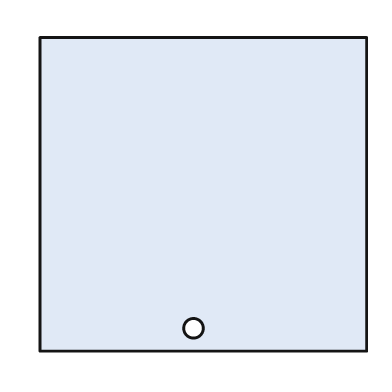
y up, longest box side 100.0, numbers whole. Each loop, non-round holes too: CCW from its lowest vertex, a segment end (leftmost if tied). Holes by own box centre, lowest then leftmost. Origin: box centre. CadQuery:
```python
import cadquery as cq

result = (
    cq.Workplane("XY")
    .moveTo(-50.0, -48.0)
    .lineTo(50.0, -48.0)
    .lineTo(50.0, 48.0)
    .lineTo(-50.0, 48.0)
    .close()
    .moveTo(-3.0, -41.0)
    .circle(3.0)
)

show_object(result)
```